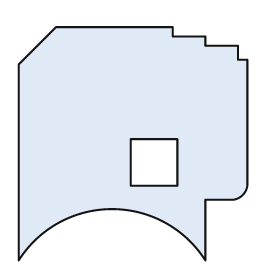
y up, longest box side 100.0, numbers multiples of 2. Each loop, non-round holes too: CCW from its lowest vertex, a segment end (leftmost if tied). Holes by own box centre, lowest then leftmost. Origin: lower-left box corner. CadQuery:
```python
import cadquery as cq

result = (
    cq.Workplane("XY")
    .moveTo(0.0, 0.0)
    .threePointArc((40.0, 22.0), (80.0, 0.0))
    .lineTo(80.0, 26.0)
    .lineTo(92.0, 26.0)
    .threePointArc((96.0, 28.0), (98.0, 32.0))
    .lineTo(98.0, 86.0)
    .lineTo(94.0, 86.0)
    .lineTo(94.0, 92.0)
    .lineTo(80.0, 92.0)
    .lineTo(80.0, 96.0)
    .lineTo(66.0, 96.0)
    .lineTo(66.0, 100.0)
    .lineTo(16.0, 100.0)
    .lineTo(0.0, 84.0)
    .close()
    .moveTo(48.0, 32.0)
    .lineTo(68.0, 32.0)
    .lineTo(68.0, 52.0)
    .lineTo(48.0, 52.0)
    .close()
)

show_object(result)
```